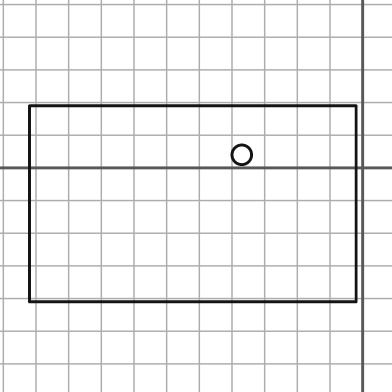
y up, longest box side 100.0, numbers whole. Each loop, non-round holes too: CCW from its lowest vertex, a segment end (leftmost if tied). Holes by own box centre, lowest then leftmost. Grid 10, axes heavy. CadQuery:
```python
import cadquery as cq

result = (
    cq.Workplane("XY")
    .moveTo(-102.0, -41.0)
    .lineTo(-2.0, -41.0)
    .lineTo(-2.0, 19.0)
    .lineTo(-102.0, 19.0)
    .close()
    .moveTo(-37.0, 4.0)
    .circle(3.0)
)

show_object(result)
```